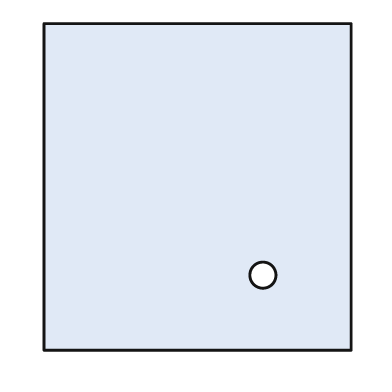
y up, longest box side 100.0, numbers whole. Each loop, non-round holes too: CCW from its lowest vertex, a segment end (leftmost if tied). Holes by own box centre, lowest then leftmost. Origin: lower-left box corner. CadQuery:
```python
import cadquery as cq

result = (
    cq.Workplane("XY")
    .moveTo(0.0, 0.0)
    .lineTo(94.0, 0.0)
    .lineTo(94.0, 100.0)
    .lineTo(0.0, 100.0)
    .close()
    .moveTo(67.0, 23.0)
    .circle(4.0)
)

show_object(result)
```